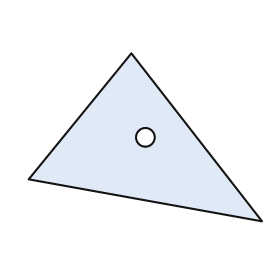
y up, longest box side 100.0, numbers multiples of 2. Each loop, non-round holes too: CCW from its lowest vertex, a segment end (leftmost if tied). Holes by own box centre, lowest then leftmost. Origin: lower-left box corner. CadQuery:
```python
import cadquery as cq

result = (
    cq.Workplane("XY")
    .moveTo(100.0, 0.0)
    .lineTo(44.0, 72.0)
    .lineTo(0.0, 18.0)
    .close()
    .moveTo(50.0, 36.0)
    .circle(4.0)
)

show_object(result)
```